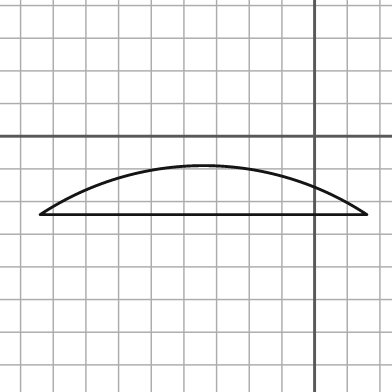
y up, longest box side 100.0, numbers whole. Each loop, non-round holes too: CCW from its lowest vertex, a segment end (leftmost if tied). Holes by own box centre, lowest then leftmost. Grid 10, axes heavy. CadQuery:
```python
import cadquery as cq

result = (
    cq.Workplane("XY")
    .moveTo(-84.0, -24.0)
    .lineTo(16.0, -24.0)
    .threePointArc((-34.0, -9.0), (-84.0, -24.0))
    .close()
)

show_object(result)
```